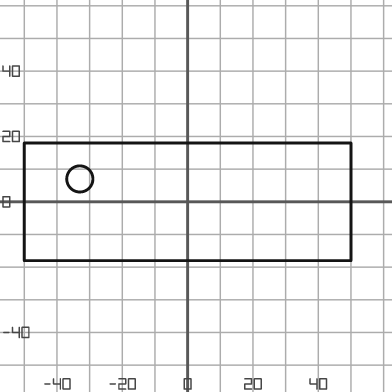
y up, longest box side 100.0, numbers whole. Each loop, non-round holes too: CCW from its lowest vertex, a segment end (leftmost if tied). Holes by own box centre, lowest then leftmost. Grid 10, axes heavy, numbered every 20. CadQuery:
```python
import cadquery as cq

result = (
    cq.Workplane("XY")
    .moveTo(-50.0, -18.0)
    .lineTo(50.0, -18.0)
    .lineTo(50.0, 18.0)
    .lineTo(-50.0, 18.0)
    .close()
    .moveTo(-33.0, 7.0)
    .circle(4.0)
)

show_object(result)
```